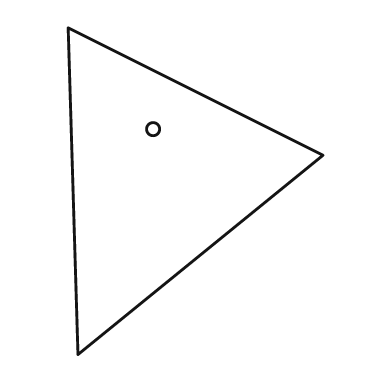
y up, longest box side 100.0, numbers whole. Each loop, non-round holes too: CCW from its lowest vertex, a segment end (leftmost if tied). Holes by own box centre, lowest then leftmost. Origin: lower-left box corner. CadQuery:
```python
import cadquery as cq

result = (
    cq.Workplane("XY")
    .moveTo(3.0, 0.0)
    .lineTo(78.0, 61.0)
    .lineTo(0.0, 100.0)
    .close()
    .moveTo(26.0, 69.0)
    .circle(2.0)
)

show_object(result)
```